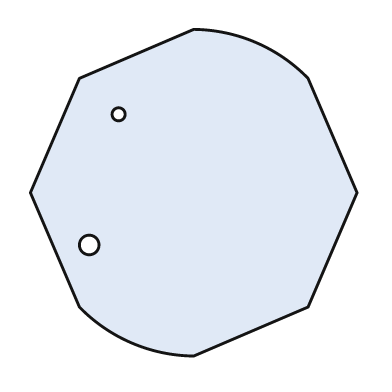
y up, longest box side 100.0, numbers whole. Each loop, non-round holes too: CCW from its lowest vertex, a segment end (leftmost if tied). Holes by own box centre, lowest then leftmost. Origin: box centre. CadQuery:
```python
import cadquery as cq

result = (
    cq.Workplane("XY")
    .moveTo(0.0, -50.0)
    .lineTo(35.0, -35.0)
    .lineTo(50.0, 0.0)
    .lineTo(35.0, 35.0)
    .threePointArc((19.0, 46.0), (0.0, 50.0))
    .lineTo(-35.0, 35.0)
    .lineTo(-50.0, 0.0)
    .lineTo(-35.0, -35.0)
    .threePointArc((-19.0, -46.0), (0.0, -50.0))
    .close()
    .moveTo(-32.0, -16.0)
    .circle(3.0)
    .moveTo(-23.0, 24.0)
    .circle(2.0)
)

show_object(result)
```